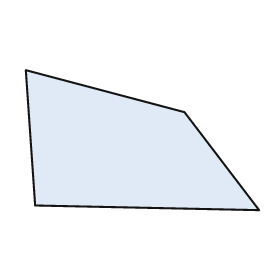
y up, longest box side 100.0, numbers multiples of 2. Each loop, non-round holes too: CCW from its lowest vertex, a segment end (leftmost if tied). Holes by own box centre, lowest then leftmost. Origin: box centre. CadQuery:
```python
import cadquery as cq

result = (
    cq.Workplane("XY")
    .moveTo(50.0, -30.0)
    .lineTo(18.0, 12.0)
    .lineTo(-50.0, 30.0)
    .lineTo(-46.0, -28.0)
    .close()
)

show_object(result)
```